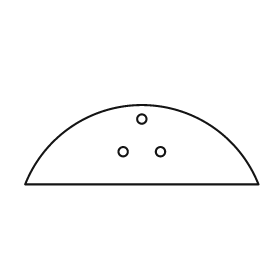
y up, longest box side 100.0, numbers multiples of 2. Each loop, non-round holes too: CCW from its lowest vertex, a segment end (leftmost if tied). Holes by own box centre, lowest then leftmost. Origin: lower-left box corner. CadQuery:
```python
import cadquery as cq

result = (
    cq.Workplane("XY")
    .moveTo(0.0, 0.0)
    .lineTo(100.0, 0.0)
    .threePointArc((50.0, 34.0), (0.0, 0.0))
    .close()
    .moveTo(42.0, 14.0)
    .circle(2.0)
    .moveTo(58.0, 14.0)
    .circle(2.0)
    .moveTo(50.0, 28.0)
    .circle(2.0)
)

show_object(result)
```